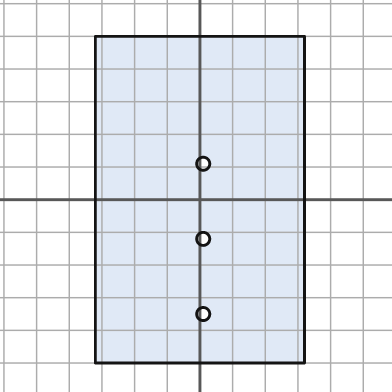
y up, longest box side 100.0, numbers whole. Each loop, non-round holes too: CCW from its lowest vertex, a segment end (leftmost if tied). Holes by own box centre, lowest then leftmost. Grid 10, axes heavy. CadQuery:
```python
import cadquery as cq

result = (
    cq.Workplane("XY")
    .moveTo(-32.0, -50.0)
    .lineTo(32.0, -50.0)
    .lineTo(32.0, 50.0)
    .lineTo(-32.0, 50.0)
    .close()
    .moveTo(1.0, -35.0)
    .circle(2.0)
    .moveTo(1.0, -12.0)
    .circle(2.0)
    .moveTo(1.0, 11.0)
    .circle(2.0)
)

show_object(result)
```